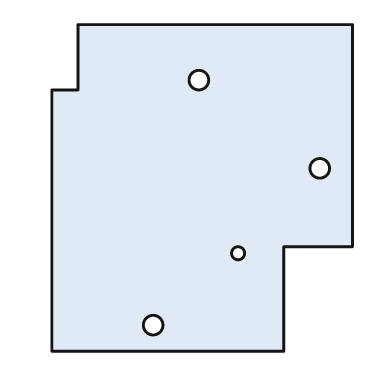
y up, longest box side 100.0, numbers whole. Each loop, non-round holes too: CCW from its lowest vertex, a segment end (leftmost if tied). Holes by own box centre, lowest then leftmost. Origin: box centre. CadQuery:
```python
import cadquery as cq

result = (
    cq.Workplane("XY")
    .moveTo(-46.0, -50.0)
    .lineTo(25.0, -50.0)
    .lineTo(25.0, -18.0)
    .lineTo(46.0, -18.0)
    .lineTo(46.0, 50.0)
    .lineTo(-38.0, 50.0)
    .lineTo(-38.0, 30.0)
    .lineTo(-46.0, 30.0)
    .close()
    .moveTo(-15.0, -42.0)
    .circle(3.0)
    .moveTo(11.0, -20.0)
    .circle(2.0)
    .moveTo(36.0, 6.0)
    .circle(3.0)
    .moveTo(-1.0, 33.0)
    .circle(3.0)
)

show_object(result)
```